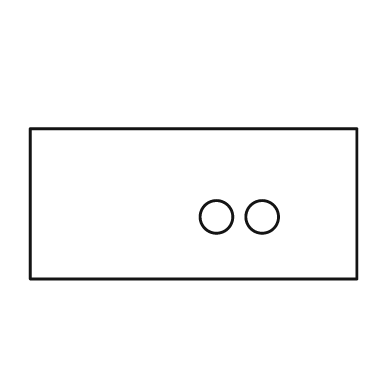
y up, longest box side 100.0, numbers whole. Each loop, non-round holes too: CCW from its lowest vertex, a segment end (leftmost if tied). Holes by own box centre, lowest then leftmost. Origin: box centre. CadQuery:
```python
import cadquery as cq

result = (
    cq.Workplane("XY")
    .moveTo(-50.0, -23.0)
    .lineTo(50.0, -23.0)
    .lineTo(50.0, 23.0)
    .lineTo(-50.0, 23.0)
    .close()
    .moveTo(7.0, -4.0)
    .circle(5.0)
    .moveTo(21.0, -4.0)
    .circle(5.0)
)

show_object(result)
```